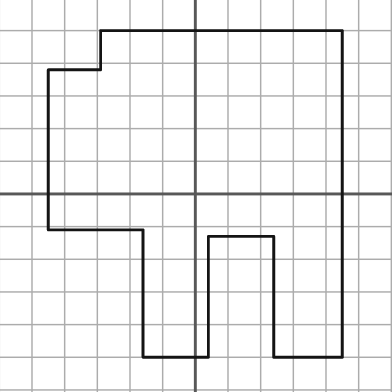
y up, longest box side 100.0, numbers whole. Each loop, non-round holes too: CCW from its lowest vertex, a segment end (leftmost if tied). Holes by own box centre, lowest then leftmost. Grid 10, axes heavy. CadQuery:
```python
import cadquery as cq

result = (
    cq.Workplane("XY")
    .moveTo(-16.0, -50.0)
    .lineTo(4.0, -50.0)
    .lineTo(4.0, -13.0)
    .lineTo(24.0, -13.0)
    .lineTo(24.0, -50.0)
    .lineTo(45.0, -50.0)
    .lineTo(45.0, 50.0)
    .lineTo(-29.0, 50.0)
    .lineTo(-29.0, 38.0)
    .lineTo(-45.0, 38.0)
    .lineTo(-45.0, -11.0)
    .lineTo(-16.0, -11.0)
    .close()
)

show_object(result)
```